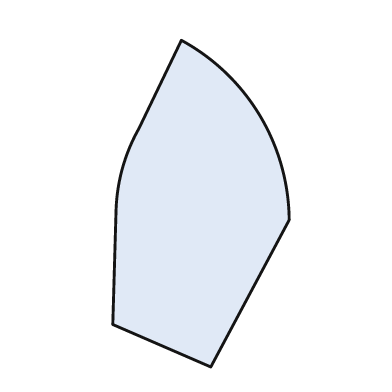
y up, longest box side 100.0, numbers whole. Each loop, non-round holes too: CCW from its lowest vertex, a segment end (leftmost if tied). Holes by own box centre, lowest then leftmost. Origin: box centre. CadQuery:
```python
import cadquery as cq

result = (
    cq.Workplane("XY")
    .moveTo(3.0, -50.0)
    .lineTo(27.0, -5.0)
    .threePointArc((18.0, 27.0), (-6.0, 50.0))
    .lineTo(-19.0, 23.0)
    .threePointArc((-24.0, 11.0), (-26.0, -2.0))
    .lineTo(-27.0, -37.0)
    .close()
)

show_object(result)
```